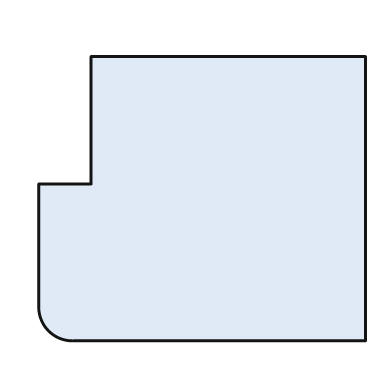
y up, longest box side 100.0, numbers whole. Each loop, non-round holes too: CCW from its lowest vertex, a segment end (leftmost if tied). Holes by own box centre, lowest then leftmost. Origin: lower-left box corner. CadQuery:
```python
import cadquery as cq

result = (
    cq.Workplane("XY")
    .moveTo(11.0, 0.0)
    .lineTo(100.0, 0.0)
    .lineTo(100.0, 87.0)
    .lineTo(16.0, 87.0)
    .lineTo(16.0, 48.0)
    .lineTo(0.0, 48.0)
    .lineTo(0.0, 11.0)
    .threePointArc((3.0, 3.0), (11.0, 0.0))
    .close()
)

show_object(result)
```